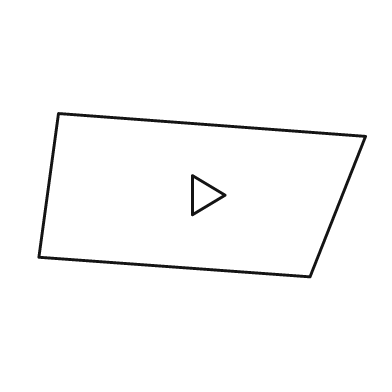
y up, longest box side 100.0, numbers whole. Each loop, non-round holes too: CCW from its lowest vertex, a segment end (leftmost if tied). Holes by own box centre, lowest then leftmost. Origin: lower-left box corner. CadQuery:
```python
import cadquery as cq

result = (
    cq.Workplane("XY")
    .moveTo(83.0, 0.0)
    .lineTo(100.0, 43.0)
    .lineTo(6.0, 50.0)
    .lineTo(0.0, 6.0)
    .close()
    .moveTo(47.0, 19.0)
    .lineTo(57.0, 25.0)
    .lineTo(47.0, 31.0)
    .close()
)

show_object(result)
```